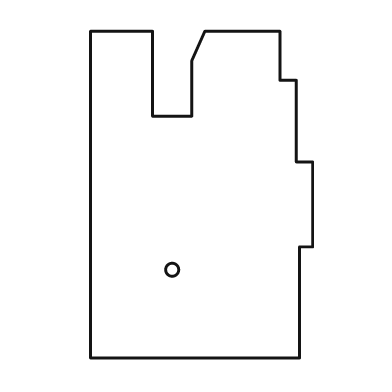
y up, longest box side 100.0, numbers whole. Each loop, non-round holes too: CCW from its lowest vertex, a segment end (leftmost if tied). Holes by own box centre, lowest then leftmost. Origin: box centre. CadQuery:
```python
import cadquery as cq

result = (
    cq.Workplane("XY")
    .moveTo(-34.0, -50.0)
    .lineTo(30.0, -50.0)
    .lineTo(30.0, -16.0)
    .lineTo(34.0, -16.0)
    .lineTo(34.0, 10.0)
    .lineTo(29.0, 10.0)
    .lineTo(29.0, 35.0)
    .lineTo(24.0, 35.0)
    .lineTo(24.0, 50.0)
    .lineTo(1.0, 50.0)
    .lineTo(-3.0, 41.0)
    .lineTo(-3.0, 24.0)
    .lineTo(-15.0, 24.0)
    .lineTo(-15.0, 50.0)
    .lineTo(-34.0, 50.0)
    .close()
    .moveTo(-9.0, -23.0)
    .circle(2.0)
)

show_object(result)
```